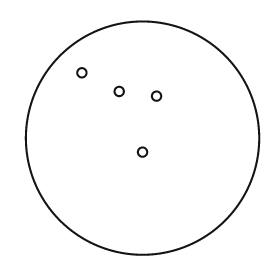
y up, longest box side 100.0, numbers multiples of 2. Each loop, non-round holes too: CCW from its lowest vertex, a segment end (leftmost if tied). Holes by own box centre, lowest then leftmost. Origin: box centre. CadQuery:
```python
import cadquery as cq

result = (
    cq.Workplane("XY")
    .moveTo(0.0, 0.0)
    .circle(50.0)
    .moveTo(0.0, -6.0)
    .circle(2.0)
    .moveTo(6.0, 18.0)
    .circle(2.0)
    .moveTo(-10.0, 20.0)
    .circle(2.0)
    .moveTo(-26.0, 28.0)
    .circle(2.0)
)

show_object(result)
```